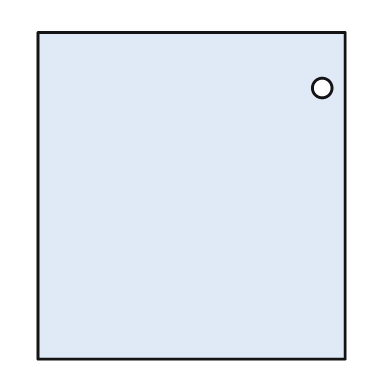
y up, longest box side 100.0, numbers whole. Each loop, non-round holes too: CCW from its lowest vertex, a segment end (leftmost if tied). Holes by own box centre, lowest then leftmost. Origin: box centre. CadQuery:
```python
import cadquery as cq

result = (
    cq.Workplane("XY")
    .moveTo(-47.0, -50.0)
    .lineTo(47.0, -50.0)
    .lineTo(47.0, 50.0)
    .lineTo(-47.0, 50.0)
    .close()
    .moveTo(40.0, 33.0)
    .circle(3.0)
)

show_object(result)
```